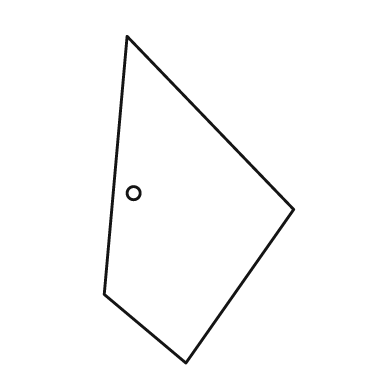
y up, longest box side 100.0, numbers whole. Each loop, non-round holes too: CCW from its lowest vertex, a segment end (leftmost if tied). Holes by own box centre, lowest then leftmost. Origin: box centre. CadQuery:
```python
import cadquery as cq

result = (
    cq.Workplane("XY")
    .moveTo(-4.0, -50.0)
    .lineTo(29.0, -3.0)
    .lineTo(-22.0, 50.0)
    .lineTo(-29.0, -29.0)
    .close()
    .moveTo(-20.0, 2.0)
    .circle(2.0)
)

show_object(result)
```